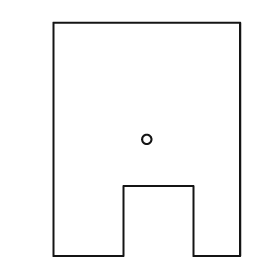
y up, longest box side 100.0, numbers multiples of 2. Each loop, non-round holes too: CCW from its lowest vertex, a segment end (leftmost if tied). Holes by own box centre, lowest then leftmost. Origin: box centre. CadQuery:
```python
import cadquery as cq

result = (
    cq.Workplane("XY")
    .moveTo(-40.0, -50.0)
    .lineTo(-10.0, -50.0)
    .lineTo(-10.0, -20.0)
    .lineTo(20.0, -20.0)
    .lineTo(20.0, -50.0)
    .lineTo(40.0, -50.0)
    .lineTo(40.0, 50.0)
    .lineTo(-40.0, 50.0)
    .close()
    .moveTo(0.0, 0.0)
    .circle(2.0)
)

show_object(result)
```